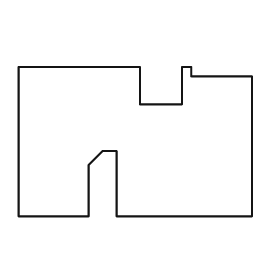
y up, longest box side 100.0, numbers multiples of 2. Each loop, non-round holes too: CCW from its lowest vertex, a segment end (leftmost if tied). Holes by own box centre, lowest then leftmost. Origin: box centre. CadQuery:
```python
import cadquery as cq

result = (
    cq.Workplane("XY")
    .moveTo(-50.0, -32.0)
    .lineTo(-20.0, -32.0)
    .lineTo(-20.0, -10.0)
    .lineTo(-14.0, -4.0)
    .lineTo(-8.0, -4.0)
    .lineTo(-8.0, -32.0)
    .lineTo(50.0, -32.0)
    .lineTo(50.0, 28.0)
    .lineTo(24.0, 28.0)
    .lineTo(24.0, 32.0)
    .lineTo(20.0, 32.0)
    .lineTo(20.0, 16.0)
    .lineTo(2.0, 16.0)
    .lineTo(2.0, 32.0)
    .lineTo(-50.0, 32.0)
    .close()
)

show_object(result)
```